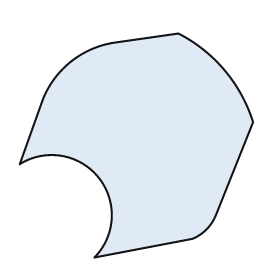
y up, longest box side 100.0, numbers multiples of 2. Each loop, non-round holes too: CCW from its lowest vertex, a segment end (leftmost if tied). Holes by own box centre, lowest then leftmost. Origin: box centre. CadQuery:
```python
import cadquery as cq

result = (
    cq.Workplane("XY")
    .moveTo(-18.0, -48.0)
    .lineTo(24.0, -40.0)
    .threePointArc((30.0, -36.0), (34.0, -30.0))
    .lineTo(50.0, 10.0)
    .threePointArc((38.0, 32.0), (18.0, 48.0))
    .lineTo(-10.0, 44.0)
    .threePointArc((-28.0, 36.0), (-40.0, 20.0))
    .lineTo(-50.0, -8.0)
    .threePointArc((-16.0, -14.0), (-18.0, -48.0))
    .close()
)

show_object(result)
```